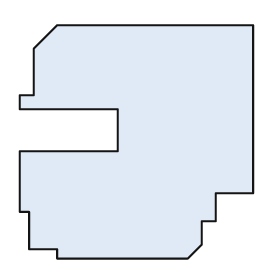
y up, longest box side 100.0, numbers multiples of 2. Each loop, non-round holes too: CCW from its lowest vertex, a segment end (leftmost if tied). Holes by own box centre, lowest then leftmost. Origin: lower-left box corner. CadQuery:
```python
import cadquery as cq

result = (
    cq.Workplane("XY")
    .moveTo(16.0, 0.0)
    .lineTo(72.0, 0.0)
    .lineTo(78.0, 6.0)
    .lineTo(78.0, 16.0)
    .lineTo(84.0, 16.0)
    .lineTo(84.0, 28.0)
    .lineTo(100.0, 28.0)
    .lineTo(100.0, 100.0)
    .lineTo(16.0, 100.0)
    .lineTo(6.0, 90.0)
    .lineTo(6.0, 70.0)
    .lineTo(0.0, 70.0)
    .lineTo(0.0, 64.0)
    .lineTo(42.0, 64.0)
    .lineTo(42.0, 46.0)
    .lineTo(0.0, 46.0)
    .lineTo(0.0, 20.0)
    .lineTo(4.0, 20.0)
    .lineTo(4.0, 4.0)
    .lineTo(16.0, 4.0)
    .close()
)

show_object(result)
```